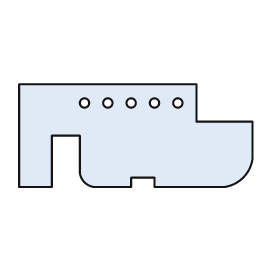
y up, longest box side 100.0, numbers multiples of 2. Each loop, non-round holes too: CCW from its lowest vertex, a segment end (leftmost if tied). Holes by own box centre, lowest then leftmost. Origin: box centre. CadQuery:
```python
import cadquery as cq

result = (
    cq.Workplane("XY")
    .moveTo(-50.0, -22.0)
    .lineTo(-36.0, -22.0)
    .lineTo(-36.0, 0.0)
    .lineTo(-24.0, 0.0)
    .lineTo(-24.0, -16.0)
    .threePointArc((-22.0, -20.0), (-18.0, -22.0))
    .lineTo(-2.0, -22.0)
    .lineTo(-2.0, -18.0)
    .lineTo(8.0, -18.0)
    .lineTo(8.0, -22.0)
    .lineTo(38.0, -22.0)
    .threePointArc((46.0, -18.0), (50.0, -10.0))
    .lineTo(50.0, 6.0)
    .lineTo(26.0, 6.0)
    .lineTo(26.0, 22.0)
    .lineTo(-50.0, 22.0)
    .close()
    .moveTo(-22.0, 14.0)
    .circle(2.0)
    .moveTo(-12.0, 14.0)
    .circle(2.0)
    .moveTo(-2.0, 14.0)
    .circle(2.0)
    .moveTo(8.0, 14.0)
    .circle(2.0)
    .moveTo(18.0, 14.0)
    .circle(2.0)
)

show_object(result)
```